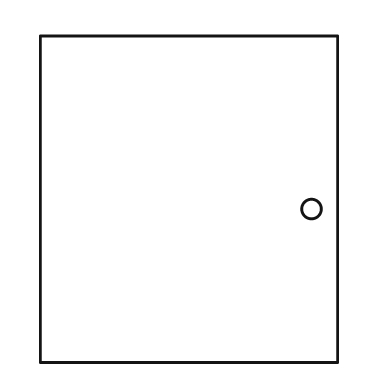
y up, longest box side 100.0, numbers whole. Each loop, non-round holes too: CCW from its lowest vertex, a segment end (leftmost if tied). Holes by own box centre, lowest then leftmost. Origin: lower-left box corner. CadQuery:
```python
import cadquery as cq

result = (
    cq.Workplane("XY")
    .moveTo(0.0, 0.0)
    .lineTo(91.0, 0.0)
    .lineTo(91.0, 100.0)
    .lineTo(0.0, 100.0)
    .close()
    .moveTo(83.0, 47.0)
    .circle(3.0)
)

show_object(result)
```